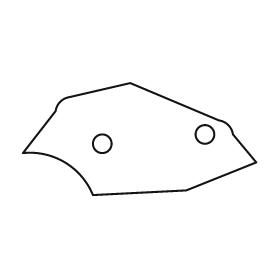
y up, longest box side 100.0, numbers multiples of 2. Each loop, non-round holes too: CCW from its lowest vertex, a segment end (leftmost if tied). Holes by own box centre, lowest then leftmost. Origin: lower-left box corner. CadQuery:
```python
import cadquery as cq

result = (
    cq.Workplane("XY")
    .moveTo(30.0, 0.0)
    .lineTo(70.0, 2.0)
    .lineTo(100.0, 14.0)
    .lineTo(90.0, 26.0)
    .threePointArc((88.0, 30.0), (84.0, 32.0))
    .lineTo(46.0, 48.0)
    .lineTo(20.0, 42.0)
    .threePointArc((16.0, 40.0), (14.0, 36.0))
    .lineTo(0.0, 18.0)
    .threePointArc((18.0, 14.0), (30.0, 0.0))
    .close()
    .moveTo(34.0, 22.0)
    .circle(4.0)
    .moveTo(78.0, 26.0)
    .circle(4.0)
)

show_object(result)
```